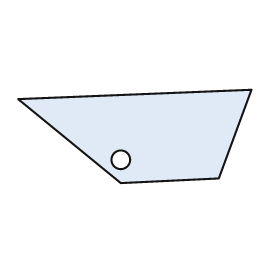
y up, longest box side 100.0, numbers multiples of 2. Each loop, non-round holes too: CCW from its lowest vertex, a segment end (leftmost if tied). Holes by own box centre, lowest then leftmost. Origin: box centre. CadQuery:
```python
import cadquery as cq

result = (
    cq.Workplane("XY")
    .moveTo(-6.0, -20.0)
    .lineTo(36.0, -18.0)
    .lineTo(50.0, 20.0)
    .lineTo(-50.0, 16.0)
    .close()
    .moveTo(-6.0, -10.0)
    .circle(4.0)
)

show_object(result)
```